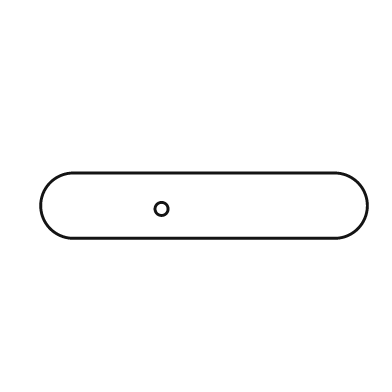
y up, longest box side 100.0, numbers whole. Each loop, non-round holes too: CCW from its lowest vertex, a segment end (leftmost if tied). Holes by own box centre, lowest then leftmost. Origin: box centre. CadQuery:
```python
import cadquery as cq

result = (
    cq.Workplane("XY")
    .moveTo(-40.0, -10.0)
    .lineTo(40.0, -10.0)
    .threePointArc((50.0, 0.0), (40.0, 10.0))
    .lineTo(-40.0, 10.0)
    .threePointArc((-50.0, 0.0), (-40.0, -10.0))
    .close()
    .moveTo(-13.0, -1.0)
    .circle(2.0)
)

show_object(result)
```